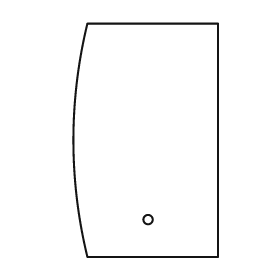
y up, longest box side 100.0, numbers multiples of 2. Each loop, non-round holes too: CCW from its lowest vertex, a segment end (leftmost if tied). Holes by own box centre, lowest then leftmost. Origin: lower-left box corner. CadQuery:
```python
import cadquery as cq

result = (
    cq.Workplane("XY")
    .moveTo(6.0, 0.0)
    .lineTo(62.0, 0.0)
    .lineTo(62.0, 100.0)
    .lineTo(6.0, 100.0)
    .threePointArc((0.0, 50.0), (6.0, 0.0))
    .close()
    .moveTo(32.0, 16.0)
    .circle(2.0)
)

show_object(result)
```